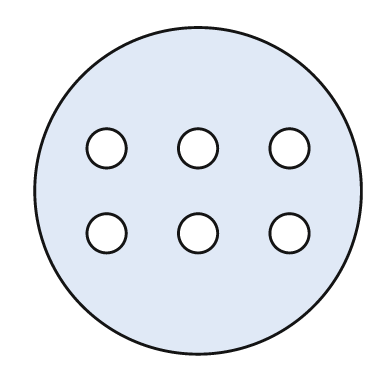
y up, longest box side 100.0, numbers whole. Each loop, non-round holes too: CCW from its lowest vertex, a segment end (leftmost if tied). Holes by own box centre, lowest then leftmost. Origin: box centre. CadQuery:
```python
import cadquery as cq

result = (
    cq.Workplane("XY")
    .moveTo(0.0, 0.0)
    .circle(50.0)
    .moveTo(-28.0, -13.0)
    .circle(6.0)
    .moveTo(0.0, -13.0)
    .circle(6.0)
    .moveTo(28.0, -13.0)
    .circle(6.0)
    .moveTo(-28.0, 13.0)
    .circle(6.0)
    .moveTo(0.0, 13.0)
    .circle(6.0)
    .moveTo(28.0, 13.0)
    .circle(6.0)
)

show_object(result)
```